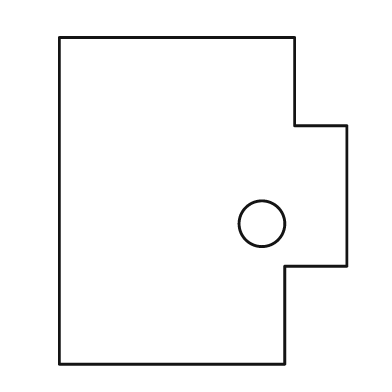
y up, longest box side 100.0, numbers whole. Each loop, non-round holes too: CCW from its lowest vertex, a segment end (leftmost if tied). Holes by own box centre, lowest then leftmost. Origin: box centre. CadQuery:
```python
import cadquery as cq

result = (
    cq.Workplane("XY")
    .moveTo(-44.0, -50.0)
    .lineTo(25.0, -50.0)
    .lineTo(25.0, -20.0)
    .lineTo(44.0, -20.0)
    .lineTo(44.0, 23.0)
    .lineTo(28.0, 23.0)
    .lineTo(28.0, 50.0)
    .lineTo(-44.0, 50.0)
    .close()
    .moveTo(18.0, -7.0)
    .circle(7.0)
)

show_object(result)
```